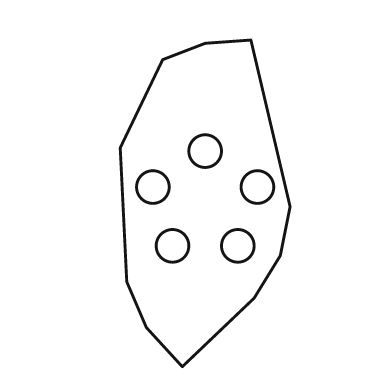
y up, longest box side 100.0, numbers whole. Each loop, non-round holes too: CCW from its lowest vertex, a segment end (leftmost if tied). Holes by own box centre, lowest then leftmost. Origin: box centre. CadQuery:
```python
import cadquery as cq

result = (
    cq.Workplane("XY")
    .moveTo(-7.0, -50.0)
    .lineTo(15.0, -29.0)
    .lineTo(23.0, -16.0)
    .lineTo(26.0, -1.0)
    .lineTo(14.0, 50.0)
    .lineTo(0.0, 49.0)
    .lineTo(-13.0, 44.0)
    .lineTo(-26.0, 17.0)
    .lineTo(-24.0, -24.0)
    .lineTo(-18.0, -38.0)
    .close()
    .moveTo(-10.0, -13.0)
    .circle(5.0)
    .moveTo(10.0, -13.0)
    .circle(5.0)
    .moveTo(-16.0, 5.0)
    .circle(5.0)
    .moveTo(16.0, 5.0)
    .circle(5.0)
    .moveTo(0.0, 16.0)
    .circle(5.0)
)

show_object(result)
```